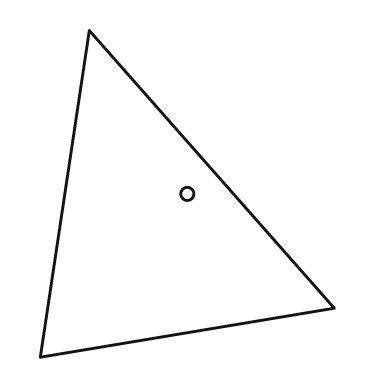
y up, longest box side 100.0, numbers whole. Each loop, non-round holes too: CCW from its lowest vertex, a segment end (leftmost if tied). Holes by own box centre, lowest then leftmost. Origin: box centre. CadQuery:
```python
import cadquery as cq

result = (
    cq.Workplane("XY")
    .moveTo(-45.0, -50.0)
    .lineTo(45.0, -35.0)
    .lineTo(-30.0, 50.0)
    .close()
    .moveTo(0.0, 0.0)
    .circle(2.0)
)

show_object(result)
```